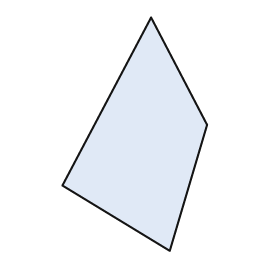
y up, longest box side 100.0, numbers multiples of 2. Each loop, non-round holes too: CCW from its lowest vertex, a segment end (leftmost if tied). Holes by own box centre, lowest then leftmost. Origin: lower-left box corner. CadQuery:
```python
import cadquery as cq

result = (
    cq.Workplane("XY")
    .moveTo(46.0, 0.0)
    .lineTo(62.0, 54.0)
    .lineTo(38.0, 100.0)
    .lineTo(0.0, 28.0)
    .close()
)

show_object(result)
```